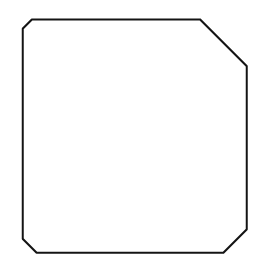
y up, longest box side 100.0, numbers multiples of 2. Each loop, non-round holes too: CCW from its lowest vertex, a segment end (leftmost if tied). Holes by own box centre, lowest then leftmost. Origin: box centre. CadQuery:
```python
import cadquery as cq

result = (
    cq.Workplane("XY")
    .moveTo(-42.0, -50.0)
    .lineTo(38.0, -50.0)
    .lineTo(48.0, -40.0)
    .lineTo(48.0, 30.0)
    .lineTo(28.0, 50.0)
    .lineTo(-44.0, 50.0)
    .lineTo(-48.0, 46.0)
    .lineTo(-48.0, -44.0)
    .close()
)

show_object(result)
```